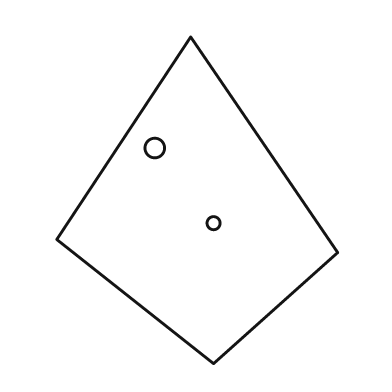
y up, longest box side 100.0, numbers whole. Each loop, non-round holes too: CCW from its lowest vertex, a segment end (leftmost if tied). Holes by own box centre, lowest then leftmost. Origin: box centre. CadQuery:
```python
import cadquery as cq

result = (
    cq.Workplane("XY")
    .moveTo(5.0, -50.0)
    .lineTo(43.0, -16.0)
    .lineTo(-2.0, 50.0)
    .lineTo(-43.0, -12.0)
    .close()
    .moveTo(5.0, -7.0)
    .circle(2.0)
    .moveTo(-13.0, 16.0)
    .circle(3.0)
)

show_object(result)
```